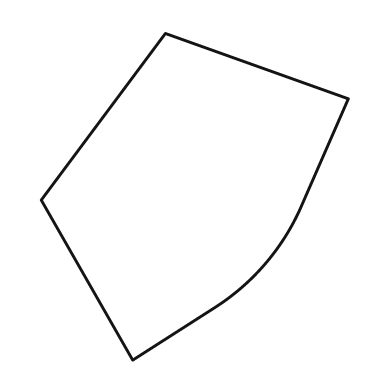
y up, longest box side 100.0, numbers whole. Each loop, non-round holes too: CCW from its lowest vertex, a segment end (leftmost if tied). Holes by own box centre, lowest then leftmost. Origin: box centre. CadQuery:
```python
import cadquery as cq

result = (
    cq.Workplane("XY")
    .moveTo(-19.0, -50.0)
    .lineTo(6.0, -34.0)
    .threePointArc((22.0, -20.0), (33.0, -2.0))
    .lineTo(47.0, 30.0)
    .lineTo(-9.0, 50.0)
    .lineTo(-47.0, -1.0)
    .close()
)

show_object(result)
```